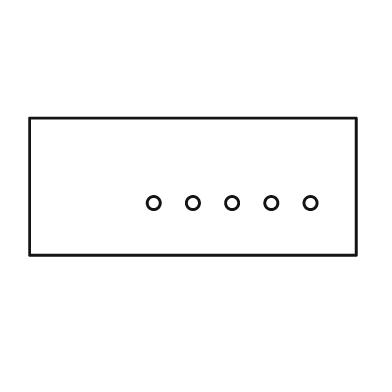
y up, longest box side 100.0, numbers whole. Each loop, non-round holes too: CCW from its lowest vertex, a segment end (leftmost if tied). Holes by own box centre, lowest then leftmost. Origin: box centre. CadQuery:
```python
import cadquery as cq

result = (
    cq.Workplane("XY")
    .moveTo(-50.0, -21.0)
    .lineTo(50.0, -21.0)
    .lineTo(50.0, 21.0)
    .lineTo(-50.0, 21.0)
    .close()
    .moveTo(-12.0, -5.0)
    .circle(2.0)
    .moveTo(0.0, -5.0)
    .circle(2.0)
    .moveTo(12.0, -5.0)
    .circle(2.0)
    .moveTo(24.0, -5.0)
    .circle(2.0)
    .moveTo(36.0, -5.0)
    .circle(2.0)
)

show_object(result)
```